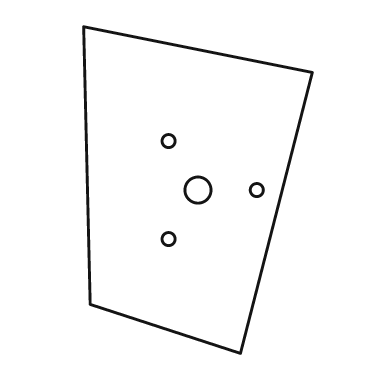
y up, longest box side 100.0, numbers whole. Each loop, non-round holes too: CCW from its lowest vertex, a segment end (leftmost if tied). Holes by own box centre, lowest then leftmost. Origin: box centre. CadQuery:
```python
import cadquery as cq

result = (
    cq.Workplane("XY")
    .moveTo(13.0, -50.0)
    .lineTo(35.0, 36.0)
    .lineTo(-35.0, 50.0)
    .lineTo(-33.0, -35.0)
    .close()
    .moveTo(-9.0, -15.0)
    .circle(2.0)
    .moveTo(0.0, 0.0)
    .circle(4.0)
    .moveTo(18.0, 0.0)
    .circle(2.0)
    .moveTo(-9.0, 15.0)
    .circle(2.0)
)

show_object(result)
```